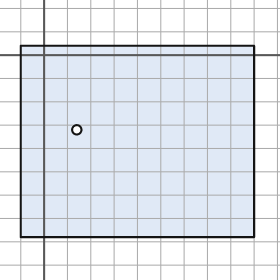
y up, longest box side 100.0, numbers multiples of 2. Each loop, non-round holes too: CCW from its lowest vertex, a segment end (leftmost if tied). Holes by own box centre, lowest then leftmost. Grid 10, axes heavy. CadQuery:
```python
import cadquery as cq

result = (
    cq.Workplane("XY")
    .moveTo(-10.0, -78.0)
    .lineTo(90.0, -78.0)
    .lineTo(90.0, 4.0)
    .lineTo(-10.0, 4.0)
    .close()
    .moveTo(14.0, -32.0)
    .circle(2.0)
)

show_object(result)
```